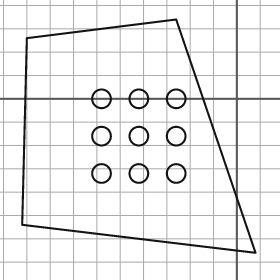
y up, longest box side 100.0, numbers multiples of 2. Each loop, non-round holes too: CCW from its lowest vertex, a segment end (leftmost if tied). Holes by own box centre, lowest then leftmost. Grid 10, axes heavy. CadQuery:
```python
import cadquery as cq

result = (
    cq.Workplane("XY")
    .moveTo(8.0, -66.0)
    .lineTo(-26.0, 34.0)
    .lineTo(-90.0, 26.0)
    .lineTo(-92.0, -54.0)
    .close()
    .moveTo(-58.0, -32.0)
    .circle(4.0)
    .moveTo(-42.0, -32.0)
    .circle(4.0)
    .moveTo(-26.0, -32.0)
    .circle(4.0)
    .moveTo(-58.0, -16.0)
    .circle(4.0)
    .moveTo(-42.0, -16.0)
    .circle(4.0)
    .moveTo(-26.0, -16.0)
    .circle(4.0)
    .moveTo(-58.0, 0.0)
    .circle(4.0)
    .moveTo(-42.0, 0.0)
    .circle(4.0)
    .moveTo(-26.0, 0.0)
    .circle(4.0)
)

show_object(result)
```